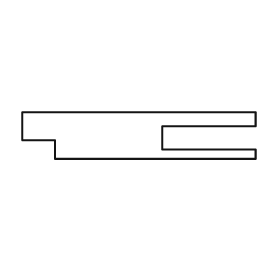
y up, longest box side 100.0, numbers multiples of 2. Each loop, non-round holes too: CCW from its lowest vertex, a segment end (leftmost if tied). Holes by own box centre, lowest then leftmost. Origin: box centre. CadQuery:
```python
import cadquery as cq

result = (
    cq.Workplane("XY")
    .moveTo(-36.0, -10.0)
    .lineTo(50.0, -10.0)
    .lineTo(50.0, -6.0)
    .lineTo(10.0, -6.0)
    .lineTo(10.0, 4.0)
    .lineTo(50.0, 4.0)
    .lineTo(50.0, 10.0)
    .lineTo(-50.0, 10.0)
    .lineTo(-50.0, -2.0)
    .lineTo(-36.0, -2.0)
    .close()
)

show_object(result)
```